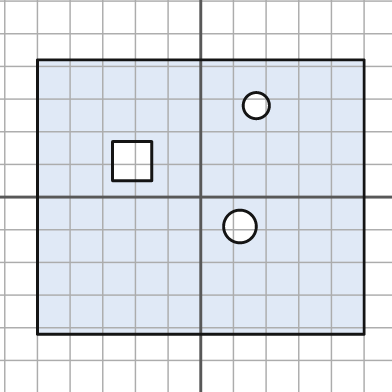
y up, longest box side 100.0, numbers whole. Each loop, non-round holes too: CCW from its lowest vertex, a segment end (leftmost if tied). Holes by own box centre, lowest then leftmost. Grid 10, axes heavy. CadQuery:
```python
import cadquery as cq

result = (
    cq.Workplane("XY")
    .moveTo(-50.0, -42.0)
    .lineTo(50.0, -42.0)
    .lineTo(50.0, 42.0)
    .lineTo(-50.0, 42.0)
    .close()
    .moveTo(12.0, -9.0)
    .circle(5.0)
    .moveTo(-27.0, 5.0)
    .lineTo(-15.0, 5.0)
    .lineTo(-15.0, 17.0)
    .lineTo(-27.0, 17.0)
    .close()
    .moveTo(17.0, 28.0)
    .circle(4.0)
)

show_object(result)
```